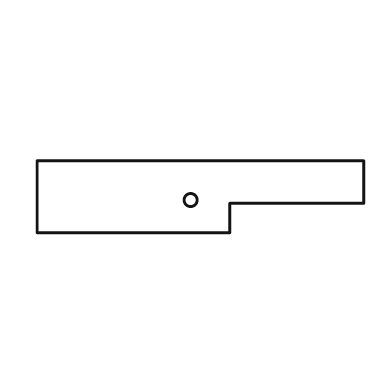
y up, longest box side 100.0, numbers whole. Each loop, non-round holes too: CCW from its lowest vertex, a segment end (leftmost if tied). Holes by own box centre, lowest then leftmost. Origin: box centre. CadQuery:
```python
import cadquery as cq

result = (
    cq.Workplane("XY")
    .moveTo(-50.0, -11.0)
    .lineTo(9.0, -11.0)
    .lineTo(9.0, -2.0)
    .lineTo(50.0, -2.0)
    .lineTo(50.0, 11.0)
    .lineTo(-50.0, 11.0)
    .close()
    .moveTo(-3.0, -1.0)
    .circle(2.0)
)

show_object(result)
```